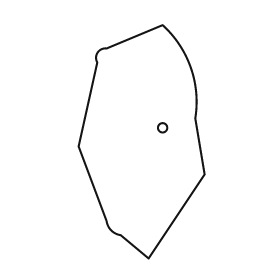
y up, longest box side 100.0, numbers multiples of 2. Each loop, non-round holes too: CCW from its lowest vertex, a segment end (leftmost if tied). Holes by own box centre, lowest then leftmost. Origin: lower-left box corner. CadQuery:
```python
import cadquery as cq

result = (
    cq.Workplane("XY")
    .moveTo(30.0, 0.0)
    .lineTo(54.0, 36.0)
    .lineTo(50.0, 60.0)
    .threePointArc((48.0, 82.0), (36.0, 100.0))
    .lineTo(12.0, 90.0)
    .threePointArc((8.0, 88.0), (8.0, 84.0))
    .lineTo(0.0, 48.0)
    .lineTo(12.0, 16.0)
    .threePointArc((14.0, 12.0), (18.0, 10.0))
    .close()
    .moveTo(36.0, 56.0)
    .circle(2.0)
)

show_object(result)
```